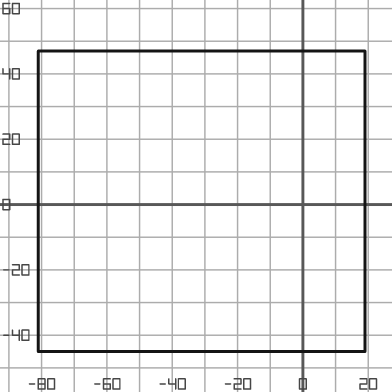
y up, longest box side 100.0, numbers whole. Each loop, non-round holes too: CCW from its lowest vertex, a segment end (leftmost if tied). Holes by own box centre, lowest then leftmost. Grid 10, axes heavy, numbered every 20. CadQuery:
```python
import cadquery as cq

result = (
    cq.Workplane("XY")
    .moveTo(-81.0, -45.0)
    .lineTo(19.0, -45.0)
    .lineTo(19.0, 47.0)
    .lineTo(-81.0, 47.0)
    .close()
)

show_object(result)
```